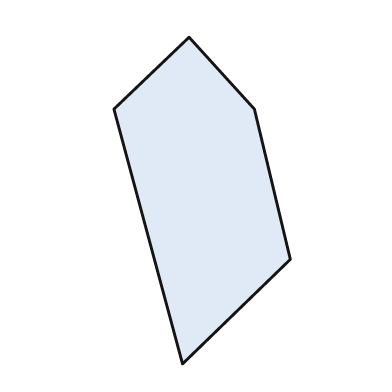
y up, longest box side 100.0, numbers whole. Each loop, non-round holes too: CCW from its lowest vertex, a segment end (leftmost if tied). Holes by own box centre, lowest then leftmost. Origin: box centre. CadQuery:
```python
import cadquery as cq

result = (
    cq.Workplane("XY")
    .moveTo(-6.0, -50.0)
    .lineTo(27.0, -18.0)
    .lineTo(16.0, 28.0)
    .lineTo(-4.0, 50.0)
    .lineTo(-27.0, 28.0)
    .close()
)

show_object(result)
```